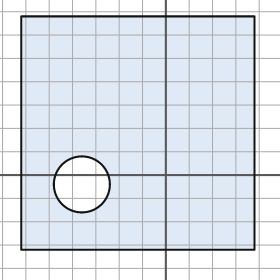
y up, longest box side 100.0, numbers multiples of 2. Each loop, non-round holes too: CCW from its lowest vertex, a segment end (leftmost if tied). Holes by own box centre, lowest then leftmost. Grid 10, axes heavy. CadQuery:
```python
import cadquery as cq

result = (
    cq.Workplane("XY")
    .moveTo(-62.0, -32.0)
    .lineTo(38.0, -32.0)
    .lineTo(38.0, 68.0)
    .lineTo(-62.0, 68.0)
    .close()
    .moveTo(-36.0, -4.0)
    .circle(12.0)
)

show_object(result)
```